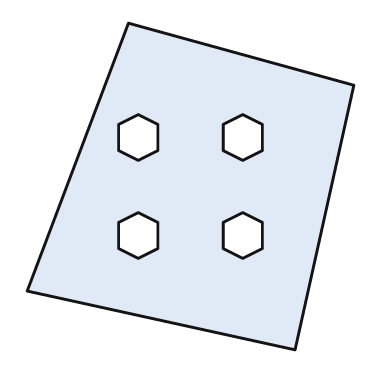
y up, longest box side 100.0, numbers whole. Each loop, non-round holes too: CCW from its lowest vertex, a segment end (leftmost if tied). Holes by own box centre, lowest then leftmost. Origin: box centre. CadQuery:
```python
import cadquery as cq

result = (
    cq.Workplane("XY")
    .moveTo(32.0, -50.0)
    .lineTo(50.0, 31.0)
    .lineTo(-19.0, 50.0)
    .lineTo(-50.0, -32.0)
    .close()
    .moveTo(-16.0, -22.0)
    .lineTo(-10.0, -19.0)
    .lineTo(-10.0, -11.0)
    .lineTo(-16.0, -8.0)
    .lineTo(-22.0, -11.0)
    .lineTo(-22.0, -19.0)
    .close()
    .moveTo(16.0, -22.0)
    .lineTo(22.0, -19.0)
    .lineTo(22.0, -11.0)
    .lineTo(16.0, -8.0)
    .lineTo(10.0, -11.0)
    .lineTo(10.0, -19.0)
    .close()
    .moveTo(-16.0, 8.0)
    .lineTo(-10.0, 11.0)
    .lineTo(-10.0, 19.0)
    .lineTo(-16.0, 22.0)
    .lineTo(-22.0, 19.0)
    .lineTo(-22.0, 11.0)
    .close()
    .moveTo(16.0, 8.0)
    .lineTo(22.0, 11.0)
    .lineTo(22.0, 19.0)
    .lineTo(16.0, 22.0)
    .lineTo(10.0, 19.0)
    .lineTo(10.0, 11.0)
    .close()
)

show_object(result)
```